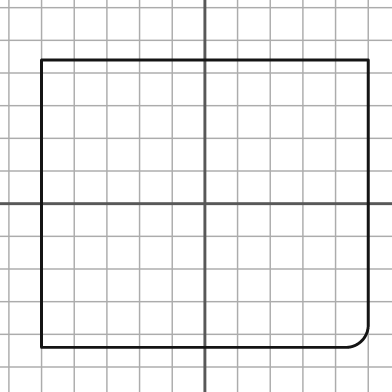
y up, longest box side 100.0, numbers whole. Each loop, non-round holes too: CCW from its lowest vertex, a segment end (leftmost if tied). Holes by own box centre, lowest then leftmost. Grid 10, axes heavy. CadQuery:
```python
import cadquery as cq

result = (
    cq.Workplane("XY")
    .moveTo(-50.0, -44.0)
    .lineTo(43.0, -44.0)
    .threePointArc((48.0, -42.0), (50.0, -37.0))
    .lineTo(50.0, 44.0)
    .lineTo(-50.0, 44.0)
    .close()
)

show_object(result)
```